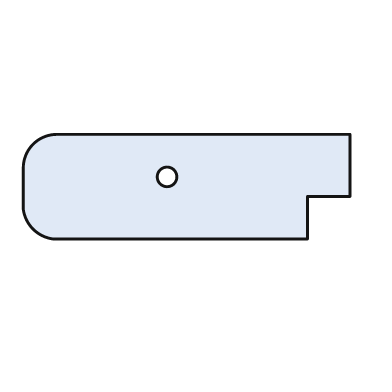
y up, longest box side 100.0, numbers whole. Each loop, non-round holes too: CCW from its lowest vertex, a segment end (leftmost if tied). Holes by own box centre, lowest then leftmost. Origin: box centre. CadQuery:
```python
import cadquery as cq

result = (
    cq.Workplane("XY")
    .moveTo(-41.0, -16.0)
    .lineTo(37.0, -16.0)
    .lineTo(37.0, -3.0)
    .lineTo(50.0, -3.0)
    .lineTo(50.0, 16.0)
    .lineTo(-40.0, 16.0)
    .threePointArc((-47.0, 13.0), (-50.0, 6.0))
    .lineTo(-50.0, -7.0)
    .threePointArc((-47.0, -13.0), (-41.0, -16.0))
    .close()
    .moveTo(-6.0, 3.0)
    .circle(3.0)
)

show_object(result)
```